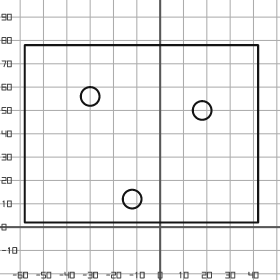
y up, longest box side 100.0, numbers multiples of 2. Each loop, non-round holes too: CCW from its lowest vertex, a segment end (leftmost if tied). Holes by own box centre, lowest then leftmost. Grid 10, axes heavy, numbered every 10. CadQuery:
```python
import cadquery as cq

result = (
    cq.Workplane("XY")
    .moveTo(-58.0, 2.0)
    .lineTo(42.0, 2.0)
    .lineTo(42.0, 78.0)
    .lineTo(-58.0, 78.0)
    .close()
    .moveTo(-12.0, 12.0)
    .circle(4.0)
    .moveTo(18.0, 50.0)
    .circle(4.0)
    .moveTo(-30.0, 56.0)
    .circle(4.0)
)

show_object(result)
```